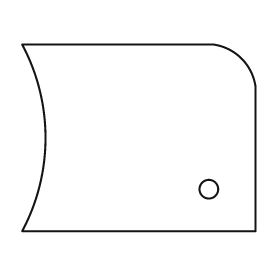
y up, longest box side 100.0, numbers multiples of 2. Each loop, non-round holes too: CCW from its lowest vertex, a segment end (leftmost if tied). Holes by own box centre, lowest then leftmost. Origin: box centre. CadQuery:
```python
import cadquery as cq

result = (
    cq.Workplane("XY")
    .moveTo(-50.0, -40.0)
    .lineTo(50.0, -40.0)
    .lineTo(50.0, 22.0)
    .threePointArc((44.0, 34.0), (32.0, 40.0))
    .lineTo(-50.0, 40.0)
    .threePointArc((-40.0, 0.0), (-50.0, -40.0))
    .close()
    .moveTo(30.0, -22.0)
    .circle(4.0)
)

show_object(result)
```